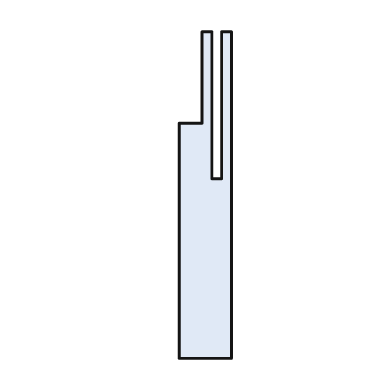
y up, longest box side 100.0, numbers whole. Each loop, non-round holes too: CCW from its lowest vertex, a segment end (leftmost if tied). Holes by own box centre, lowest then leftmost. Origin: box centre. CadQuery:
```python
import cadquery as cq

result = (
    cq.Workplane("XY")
    .moveTo(-8.0, -50.0)
    .lineTo(8.0, -50.0)
    .lineTo(8.0, 50.0)
    .lineTo(5.0, 50.0)
    .lineTo(5.0, 5.0)
    .lineTo(2.0, 5.0)
    .lineTo(2.0, 50.0)
    .lineTo(-1.0, 50.0)
    .lineTo(-1.0, 22.0)
    .lineTo(-8.0, 22.0)
    .close()
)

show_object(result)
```